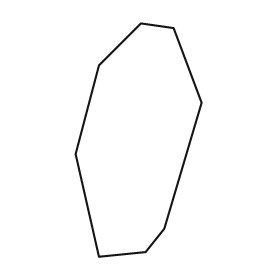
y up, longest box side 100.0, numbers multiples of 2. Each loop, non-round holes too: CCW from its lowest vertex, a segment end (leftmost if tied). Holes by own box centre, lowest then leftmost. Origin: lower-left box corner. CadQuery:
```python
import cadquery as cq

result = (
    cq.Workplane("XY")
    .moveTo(10.0, 0.0)
    .lineTo(30.0, 2.0)
    .lineTo(38.0, 12.0)
    .lineTo(54.0, 66.0)
    .lineTo(42.0, 98.0)
    .lineTo(28.0, 100.0)
    .lineTo(10.0, 82.0)
    .lineTo(0.0, 44.0)
    .close()
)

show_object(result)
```